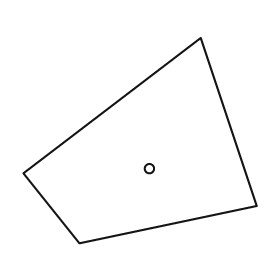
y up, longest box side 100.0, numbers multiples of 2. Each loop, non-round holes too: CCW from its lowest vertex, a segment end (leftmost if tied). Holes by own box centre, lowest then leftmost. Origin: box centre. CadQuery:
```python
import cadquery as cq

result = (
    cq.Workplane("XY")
    .moveTo(-26.0, -44.0)
    .lineTo(50.0, -28.0)
    .lineTo(26.0, 44.0)
    .lineTo(-50.0, -14.0)
    .close()
    .moveTo(4.0, -12.0)
    .circle(2.0)
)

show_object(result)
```